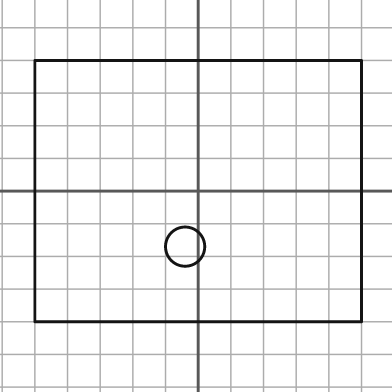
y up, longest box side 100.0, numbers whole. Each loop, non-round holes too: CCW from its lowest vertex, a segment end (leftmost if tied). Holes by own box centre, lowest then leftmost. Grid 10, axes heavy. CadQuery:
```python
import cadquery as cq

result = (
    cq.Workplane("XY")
    .moveTo(-50.0, -40.0)
    .lineTo(50.0, -40.0)
    .lineTo(50.0, 40.0)
    .lineTo(-50.0, 40.0)
    .close()
    .moveTo(-4.0, -17.0)
    .circle(6.0)
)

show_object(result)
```